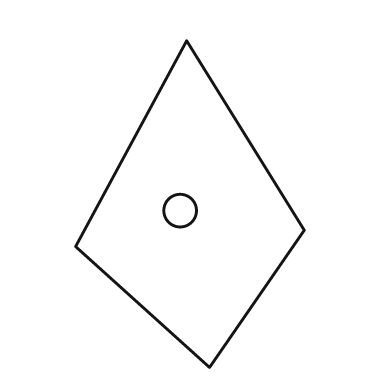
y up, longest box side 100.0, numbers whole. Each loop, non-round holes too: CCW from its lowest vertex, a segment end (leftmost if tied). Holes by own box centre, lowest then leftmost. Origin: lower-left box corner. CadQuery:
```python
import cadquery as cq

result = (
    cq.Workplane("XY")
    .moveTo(41.0, 0.0)
    .lineTo(70.0, 42.0)
    .lineTo(34.0, 100.0)
    .lineTo(0.0, 37.0)
    .close()
    .moveTo(32.0, 48.0)
    .circle(5.0)
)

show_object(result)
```